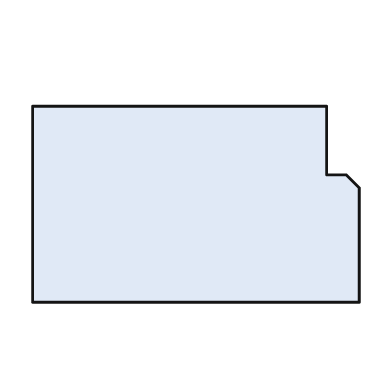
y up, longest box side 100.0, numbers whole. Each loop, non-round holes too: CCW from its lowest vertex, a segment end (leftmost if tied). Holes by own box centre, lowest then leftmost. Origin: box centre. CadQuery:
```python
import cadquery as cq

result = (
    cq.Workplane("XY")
    .moveTo(-50.0, -30.0)
    .lineTo(50.0, -30.0)
    .lineTo(50.0, 5.0)
    .lineTo(46.0, 9.0)
    .lineTo(40.0, 9.0)
    .lineTo(40.0, 30.0)
    .lineTo(-50.0, 30.0)
    .close()
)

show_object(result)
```